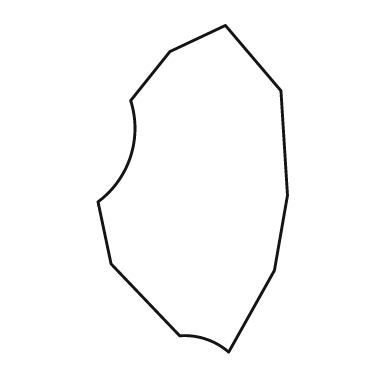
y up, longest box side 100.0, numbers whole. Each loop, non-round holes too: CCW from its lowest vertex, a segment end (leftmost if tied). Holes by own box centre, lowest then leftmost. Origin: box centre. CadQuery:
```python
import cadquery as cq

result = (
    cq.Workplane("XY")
    .moveTo(11.0, -50.0)
    .lineTo(25.0, -25.0)
    .lineTo(29.0, -2.0)
    .lineTo(27.0, 30.0)
    .lineTo(10.0, 50.0)
    .lineTo(-7.0, 42.0)
    .lineTo(-19.0, 27.0)
    .threePointArc((-19.0, 10.0), (-29.0, -4.0))
    .lineTo(-25.0, -23.0)
    .lineTo(-4.0, -45.0)
    .threePointArc((4.0, -46.0), (11.0, -50.0))
    .close()
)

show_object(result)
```